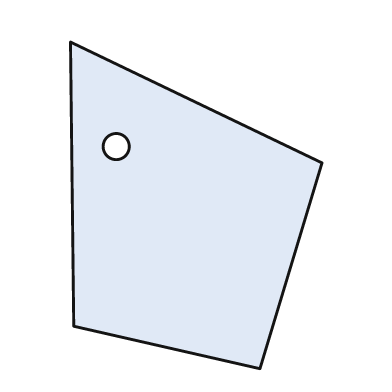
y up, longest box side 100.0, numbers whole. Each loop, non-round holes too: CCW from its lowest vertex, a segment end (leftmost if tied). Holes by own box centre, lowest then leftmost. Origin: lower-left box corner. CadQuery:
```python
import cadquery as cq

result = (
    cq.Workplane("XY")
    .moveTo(58.0, 0.0)
    .lineTo(77.0, 63.0)
    .lineTo(0.0, 100.0)
    .lineTo(1.0, 13.0)
    .close()
    .moveTo(14.0, 68.0)
    .circle(4.0)
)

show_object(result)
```